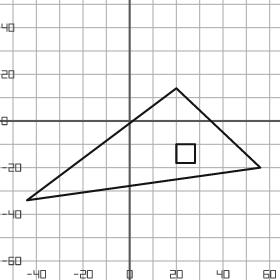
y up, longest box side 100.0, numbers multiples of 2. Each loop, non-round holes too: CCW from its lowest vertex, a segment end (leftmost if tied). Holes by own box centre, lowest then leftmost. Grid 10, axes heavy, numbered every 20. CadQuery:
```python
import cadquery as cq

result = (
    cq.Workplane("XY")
    .moveTo(-44.0, -34.0)
    .lineTo(56.0, -20.0)
    .lineTo(20.0, 14.0)
    .close()
    .moveTo(20.0, -18.0)
    .lineTo(28.0, -18.0)
    .lineTo(28.0, -10.0)
    .lineTo(20.0, -10.0)
    .close()
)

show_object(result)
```